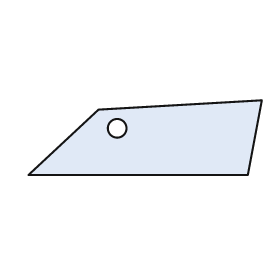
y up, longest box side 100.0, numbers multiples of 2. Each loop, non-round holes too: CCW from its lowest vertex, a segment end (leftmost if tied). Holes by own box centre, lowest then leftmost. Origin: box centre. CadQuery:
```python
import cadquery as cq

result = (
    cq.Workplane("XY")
    .moveTo(-50.0, -16.0)
    .lineTo(44.0, -16.0)
    .lineTo(50.0, 16.0)
    .lineTo(-20.0, 12.0)
    .close()
    .moveTo(-12.0, 4.0)
    .circle(4.0)
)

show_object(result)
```